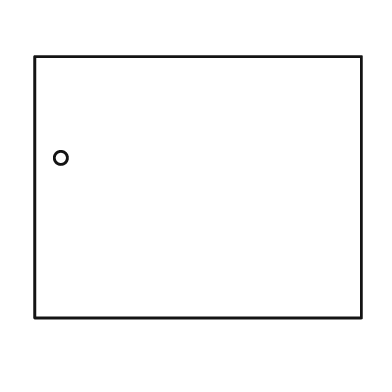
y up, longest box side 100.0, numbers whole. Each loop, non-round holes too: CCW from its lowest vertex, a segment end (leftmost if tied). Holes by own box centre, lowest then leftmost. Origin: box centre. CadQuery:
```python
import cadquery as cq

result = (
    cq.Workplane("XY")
    .moveTo(-50.0, -40.0)
    .lineTo(50.0, -40.0)
    .lineTo(50.0, 40.0)
    .lineTo(-50.0, 40.0)
    .close()
    .moveTo(-42.0, 9.0)
    .circle(2.0)
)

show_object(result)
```